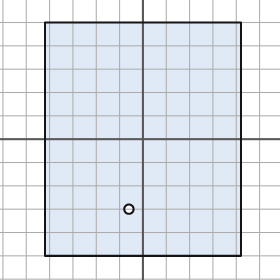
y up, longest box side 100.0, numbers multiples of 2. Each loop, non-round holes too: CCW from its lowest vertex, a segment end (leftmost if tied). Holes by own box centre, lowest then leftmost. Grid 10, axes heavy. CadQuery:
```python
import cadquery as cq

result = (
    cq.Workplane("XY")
    .moveTo(-42.0, -50.0)
    .lineTo(42.0, -50.0)
    .lineTo(42.0, 50.0)
    .lineTo(-42.0, 50.0)
    .close()
    .moveTo(-6.0, -30.0)
    .circle(2.0)
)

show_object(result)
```